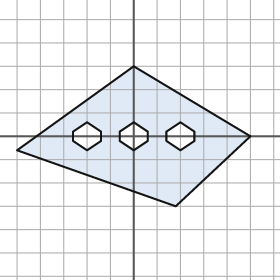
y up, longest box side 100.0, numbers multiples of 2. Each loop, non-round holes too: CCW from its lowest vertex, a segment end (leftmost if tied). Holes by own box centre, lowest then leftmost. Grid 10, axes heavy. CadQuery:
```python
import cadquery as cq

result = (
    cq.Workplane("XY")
    .moveTo(18.0, -30.0)
    .lineTo(50.0, 0.0)
    .lineTo(0.0, 30.0)
    .lineTo(-50.0, -6.0)
    .close()
    .moveTo(-20.0, -6.0)
    .lineTo(-14.0, -2.0)
    .lineTo(-14.0, 2.0)
    .lineTo(-20.0, 6.0)
    .lineTo(-26.0, 2.0)
    .lineTo(-26.0, -2.0)
    .close()
    .moveTo(0.0, -6.0)
    .lineTo(6.0, -2.0)
    .lineTo(6.0, 2.0)
    .lineTo(0.0, 6.0)
    .lineTo(-6.0, 2.0)
    .lineTo(-6.0, -2.0)
    .close()
    .moveTo(20.0, -6.0)
    .lineTo(26.0, -2.0)
    .lineTo(26.0, 2.0)
    .lineTo(20.0, 6.0)
    .lineTo(14.0, 2.0)
    .lineTo(14.0, -2.0)
    .close()
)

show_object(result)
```